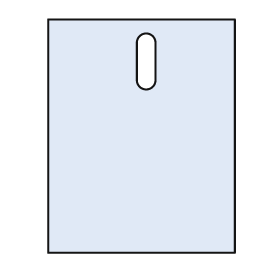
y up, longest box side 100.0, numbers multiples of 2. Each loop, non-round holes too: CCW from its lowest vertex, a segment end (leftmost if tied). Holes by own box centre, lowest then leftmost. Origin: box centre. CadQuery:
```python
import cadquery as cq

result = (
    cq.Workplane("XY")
    .moveTo(-40.0, -50.0)
    .lineTo(40.0, -50.0)
    .lineTo(40.0, 50.0)
    .lineTo(-40.0, 50.0)
    .close()
    .moveTo(-2.0, 24.0)
    .threePointArc((2.0, 20.0), (6.0, 24.0))
    .lineTo(6.0, 40.0)
    .threePointArc((2.0, 44.0), (-2.0, 40.0))
    .close()
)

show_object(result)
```